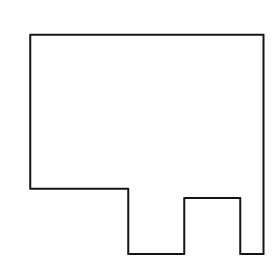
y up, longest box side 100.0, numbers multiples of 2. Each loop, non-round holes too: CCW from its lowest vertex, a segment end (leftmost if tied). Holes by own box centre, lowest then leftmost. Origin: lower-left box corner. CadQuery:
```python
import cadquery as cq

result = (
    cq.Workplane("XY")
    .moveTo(42.0, 0.0)
    .lineTo(66.0, 0.0)
    .lineTo(66.0, 24.0)
    .lineTo(90.0, 24.0)
    .lineTo(90.0, 0.0)
    .lineTo(100.0, 0.0)
    .lineTo(100.0, 94.0)
    .lineTo(0.0, 94.0)
    .lineTo(0.0, 28.0)
    .lineTo(42.0, 28.0)
    .close()
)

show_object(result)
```